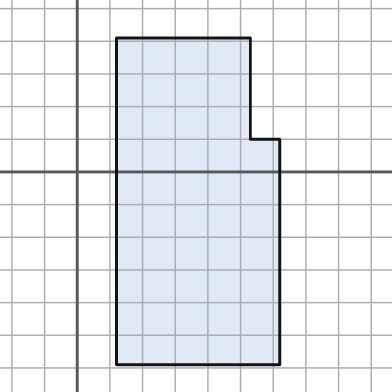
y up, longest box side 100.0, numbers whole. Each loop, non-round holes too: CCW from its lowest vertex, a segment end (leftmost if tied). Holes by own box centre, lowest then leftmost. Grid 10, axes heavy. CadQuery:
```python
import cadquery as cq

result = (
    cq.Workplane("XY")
    .moveTo(12.0, -59.0)
    .lineTo(62.0, -59.0)
    .lineTo(62.0, 10.0)
    .lineTo(53.0, 10.0)
    .lineTo(53.0, 41.0)
    .lineTo(12.0, 41.0)
    .close()
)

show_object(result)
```